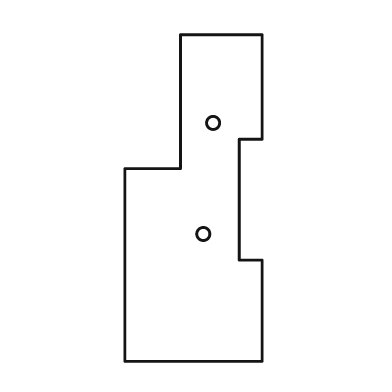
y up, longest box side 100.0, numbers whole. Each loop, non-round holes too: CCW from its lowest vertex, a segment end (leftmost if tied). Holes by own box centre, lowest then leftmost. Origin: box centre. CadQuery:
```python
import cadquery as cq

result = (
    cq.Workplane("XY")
    .moveTo(-21.0, -50.0)
    .lineTo(21.0, -50.0)
    .lineTo(21.0, -19.0)
    .lineTo(14.0, -19.0)
    .lineTo(14.0, 18.0)
    .lineTo(21.0, 18.0)
    .lineTo(21.0, 50.0)
    .lineTo(-4.0, 50.0)
    .lineTo(-4.0, 9.0)
    .lineTo(-21.0, 9.0)
    .close()
    .moveTo(3.0, -11.0)
    .circle(2.0)
    .moveTo(6.0, 23.0)
    .circle(2.0)
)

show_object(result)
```